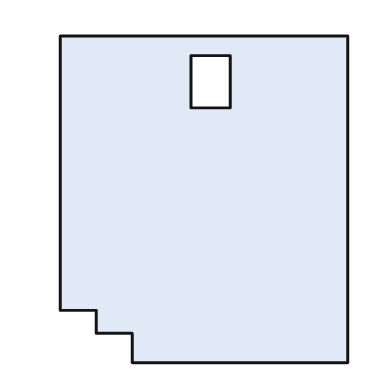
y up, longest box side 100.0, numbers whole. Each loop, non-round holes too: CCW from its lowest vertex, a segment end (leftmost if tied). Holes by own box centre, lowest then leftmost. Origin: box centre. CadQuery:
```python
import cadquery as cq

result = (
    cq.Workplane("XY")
    .moveTo(-22.0, -50.0)
    .lineTo(44.0, -50.0)
    .lineTo(44.0, 50.0)
    .lineTo(-44.0, 50.0)
    .lineTo(-44.0, -34.0)
    .lineTo(-33.0, -34.0)
    .lineTo(-33.0, -41.0)
    .lineTo(-22.0, -41.0)
    .close()
    .moveTo(-4.0, 28.0)
    .lineTo(8.0, 28.0)
    .lineTo(8.0, 44.0)
    .lineTo(-4.0, 44.0)
    .close()
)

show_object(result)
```